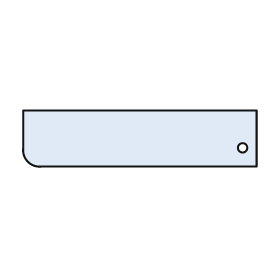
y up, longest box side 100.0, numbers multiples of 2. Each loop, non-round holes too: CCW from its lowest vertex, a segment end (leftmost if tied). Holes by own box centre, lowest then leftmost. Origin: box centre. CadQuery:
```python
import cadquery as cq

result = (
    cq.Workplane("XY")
    .moveTo(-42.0, -12.0)
    .lineTo(50.0, -12.0)
    .lineTo(50.0, 12.0)
    .lineTo(-50.0, 12.0)
    .lineTo(-50.0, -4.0)
    .threePointArc((-48.0, -10.0), (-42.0, -12.0))
    .close()
    .moveTo(44.0, -4.0)
    .circle(2.0)
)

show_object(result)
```